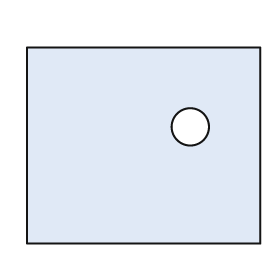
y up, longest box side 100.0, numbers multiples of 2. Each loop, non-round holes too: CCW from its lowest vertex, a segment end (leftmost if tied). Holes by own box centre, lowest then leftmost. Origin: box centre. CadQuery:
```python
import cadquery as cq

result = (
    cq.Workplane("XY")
    .moveTo(-50.0, -42.0)
    .lineTo(50.0, -42.0)
    .lineTo(50.0, 42.0)
    .lineTo(-50.0, 42.0)
    .close()
    .moveTo(20.0, 8.0)
    .circle(8.0)
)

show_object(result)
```